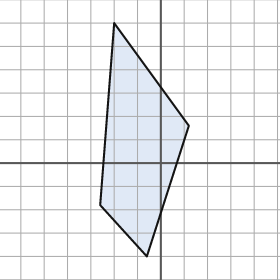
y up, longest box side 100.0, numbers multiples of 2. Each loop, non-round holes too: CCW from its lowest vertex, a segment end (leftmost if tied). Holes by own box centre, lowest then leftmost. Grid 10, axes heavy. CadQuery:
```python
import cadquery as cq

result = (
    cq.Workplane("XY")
    .moveTo(-6.0, -40.0)
    .lineTo(12.0, 16.0)
    .lineTo(-20.0, 60.0)
    .lineTo(-26.0, -18.0)
    .close()
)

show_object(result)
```